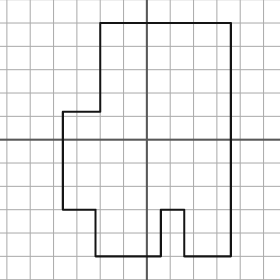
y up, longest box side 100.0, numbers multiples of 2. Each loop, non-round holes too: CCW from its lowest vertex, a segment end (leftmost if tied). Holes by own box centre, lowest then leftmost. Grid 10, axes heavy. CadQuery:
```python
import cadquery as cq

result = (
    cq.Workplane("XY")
    .moveTo(-22.0, -50.0)
    .lineTo(6.0, -50.0)
    .lineTo(6.0, -30.0)
    .lineTo(16.0, -30.0)
    .lineTo(16.0, -50.0)
    .lineTo(36.0, -50.0)
    .lineTo(36.0, 50.0)
    .lineTo(-20.0, 50.0)
    .lineTo(-20.0, 12.0)
    .lineTo(-36.0, 12.0)
    .lineTo(-36.0, -30.0)
    .lineTo(-22.0, -30.0)
    .close()
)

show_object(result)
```